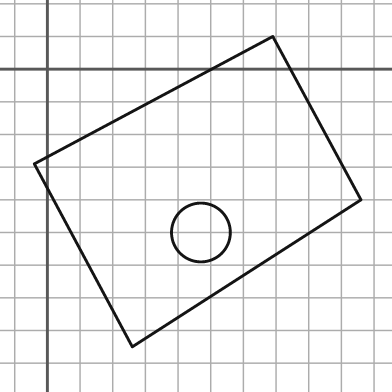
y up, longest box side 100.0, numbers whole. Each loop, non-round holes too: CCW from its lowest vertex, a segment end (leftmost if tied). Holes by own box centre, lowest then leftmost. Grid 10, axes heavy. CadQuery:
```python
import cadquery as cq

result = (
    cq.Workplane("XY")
    .moveTo(26.0, -85.0)
    .lineTo(96.0, -40.0)
    .lineTo(69.0, 10.0)
    .lineTo(-4.0, -29.0)
    .close()
    .moveTo(47.0, -50.0)
    .circle(9.0)
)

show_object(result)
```